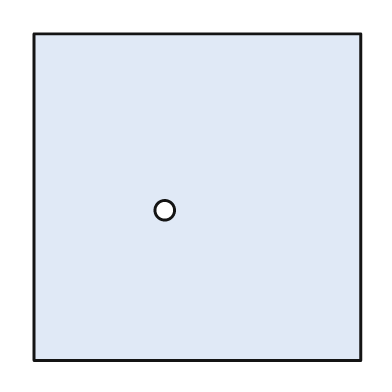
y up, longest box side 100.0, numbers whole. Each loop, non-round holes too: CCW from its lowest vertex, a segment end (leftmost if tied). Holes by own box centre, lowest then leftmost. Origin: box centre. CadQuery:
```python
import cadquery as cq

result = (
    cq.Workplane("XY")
    .moveTo(-50.0, -50.0)
    .lineTo(50.0, -50.0)
    .lineTo(50.0, 50.0)
    .lineTo(-50.0, 50.0)
    .close()
    .moveTo(-10.0, -4.0)
    .circle(3.0)
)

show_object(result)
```